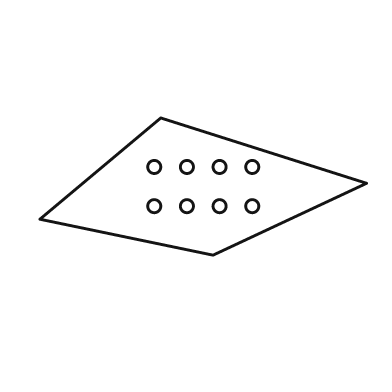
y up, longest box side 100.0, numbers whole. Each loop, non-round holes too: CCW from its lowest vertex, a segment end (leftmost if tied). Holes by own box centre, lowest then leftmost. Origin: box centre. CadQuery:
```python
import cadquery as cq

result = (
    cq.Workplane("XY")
    .moveTo(3.0, -21.0)
    .lineTo(50.0, 1.0)
    .lineTo(-13.0, 21.0)
    .lineTo(-50.0, -10.0)
    .close()
    .moveTo(-15.0, -6.0)
    .circle(2.0)
    .moveTo(-5.0, -6.0)
    .circle(2.0)
    .moveTo(5.0, -6.0)
    .circle(2.0)
    .moveTo(15.0, -6.0)
    .circle(2.0)
    .moveTo(-15.0, 6.0)
    .circle(2.0)
    .moveTo(-5.0, 6.0)
    .circle(2.0)
    .moveTo(5.0, 6.0)
    .circle(2.0)
    .moveTo(15.0, 6.0)
    .circle(2.0)
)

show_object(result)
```